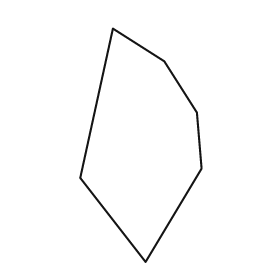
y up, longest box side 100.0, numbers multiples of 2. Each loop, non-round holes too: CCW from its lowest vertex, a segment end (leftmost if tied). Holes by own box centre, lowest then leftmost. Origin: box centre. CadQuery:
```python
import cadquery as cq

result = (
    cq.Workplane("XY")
    .moveTo(2.0, -50.0)
    .lineTo(26.0, -10.0)
    .lineTo(24.0, 14.0)
    .lineTo(10.0, 36.0)
    .lineTo(-12.0, 50.0)
    .lineTo(-26.0, -14.0)
    .close()
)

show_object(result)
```